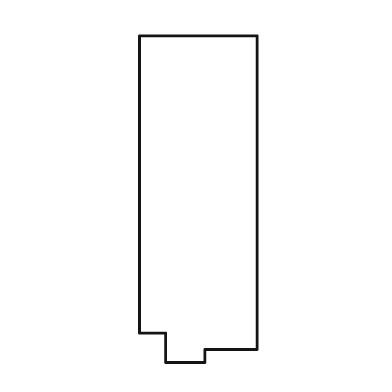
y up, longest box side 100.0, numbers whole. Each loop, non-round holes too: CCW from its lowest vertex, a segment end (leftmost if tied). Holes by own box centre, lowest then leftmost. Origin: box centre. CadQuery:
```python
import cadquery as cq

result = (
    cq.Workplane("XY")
    .moveTo(-10.0, -50.0)
    .lineTo(2.0, -50.0)
    .lineTo(2.0, -46.0)
    .lineTo(18.0, -46.0)
    .lineTo(18.0, 50.0)
    .lineTo(-18.0, 50.0)
    .lineTo(-18.0, -41.0)
    .lineTo(-10.0, -41.0)
    .close()
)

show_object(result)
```